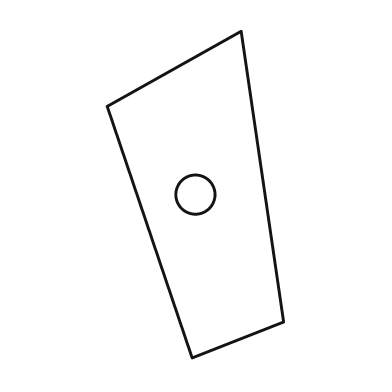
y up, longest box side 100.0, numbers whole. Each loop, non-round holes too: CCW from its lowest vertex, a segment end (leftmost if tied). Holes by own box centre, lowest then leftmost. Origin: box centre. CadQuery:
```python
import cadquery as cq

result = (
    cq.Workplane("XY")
    .moveTo(-1.0, -50.0)
    .lineTo(27.0, -39.0)
    .lineTo(14.0, 50.0)
    .lineTo(-27.0, 27.0)
    .close()
    .moveTo(0.0, 0.0)
    .circle(6.0)
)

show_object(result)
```